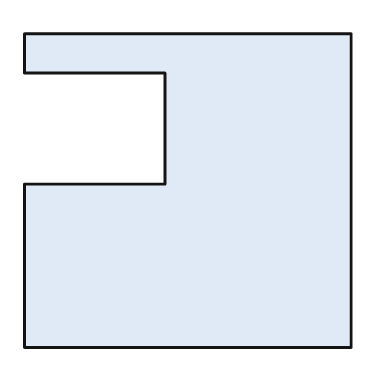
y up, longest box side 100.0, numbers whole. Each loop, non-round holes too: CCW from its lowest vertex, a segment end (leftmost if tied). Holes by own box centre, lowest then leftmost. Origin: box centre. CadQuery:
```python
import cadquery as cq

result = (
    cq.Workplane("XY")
    .moveTo(-50.0, -48.0)
    .lineTo(50.0, -48.0)
    .lineTo(50.0, 48.0)
    .lineTo(-50.0, 48.0)
    .lineTo(-50.0, 36.0)
    .lineTo(-7.0, 36.0)
    .lineTo(-7.0, 2.0)
    .lineTo(-50.0, 2.0)
    .close()
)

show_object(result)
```